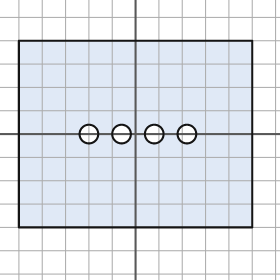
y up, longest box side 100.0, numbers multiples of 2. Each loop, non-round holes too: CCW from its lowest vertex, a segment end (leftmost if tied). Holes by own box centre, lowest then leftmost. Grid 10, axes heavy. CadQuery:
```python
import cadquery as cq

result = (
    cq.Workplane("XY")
    .moveTo(-50.0, -40.0)
    .lineTo(50.0, -40.0)
    .lineTo(50.0, 40.0)
    .lineTo(-50.0, 40.0)
    .close()
    .moveTo(-20.0, 0.0)
    .circle(4.0)
    .moveTo(-6.0, 0.0)
    .circle(4.0)
    .moveTo(8.0, 0.0)
    .circle(4.0)
    .moveTo(22.0, 0.0)
    .circle(4.0)
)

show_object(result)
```